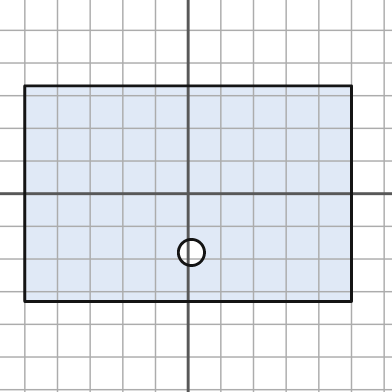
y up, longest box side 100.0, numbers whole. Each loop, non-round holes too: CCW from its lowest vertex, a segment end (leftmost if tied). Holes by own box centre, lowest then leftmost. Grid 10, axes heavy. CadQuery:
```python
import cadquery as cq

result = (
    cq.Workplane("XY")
    .moveTo(-50.0, -33.0)
    .lineTo(50.0, -33.0)
    .lineTo(50.0, 33.0)
    .lineTo(-50.0, 33.0)
    .close()
    .moveTo(1.0, -18.0)
    .circle(4.0)
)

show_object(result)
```